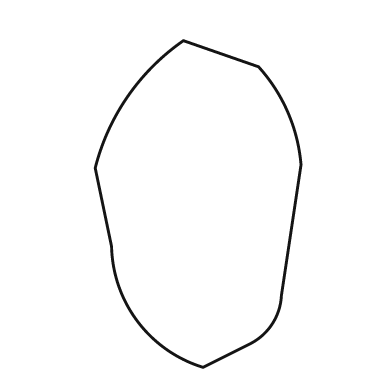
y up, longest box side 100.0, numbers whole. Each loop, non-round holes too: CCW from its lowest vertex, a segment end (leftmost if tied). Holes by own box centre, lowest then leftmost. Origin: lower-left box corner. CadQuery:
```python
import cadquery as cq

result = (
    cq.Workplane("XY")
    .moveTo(33.0, 0.0)
    .lineTo(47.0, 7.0)
    .threePointArc((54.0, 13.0), (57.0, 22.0))
    .lineTo(63.0, 62.0)
    .threePointArc((59.0, 78.0), (50.0, 92.0))
    .lineTo(27.0, 100.0)
    .threePointArc((10.0, 83.0), (0.0, 61.0))
    .lineTo(5.0, 37.0)
    .threePointArc((13.0, 14.0), (33.0, 0.0))
    .close()
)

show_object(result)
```